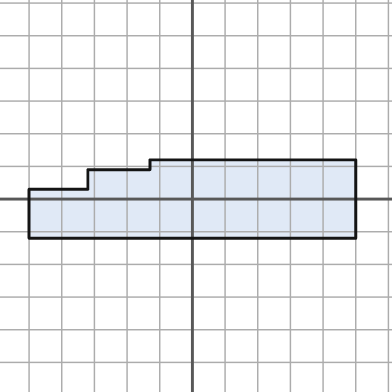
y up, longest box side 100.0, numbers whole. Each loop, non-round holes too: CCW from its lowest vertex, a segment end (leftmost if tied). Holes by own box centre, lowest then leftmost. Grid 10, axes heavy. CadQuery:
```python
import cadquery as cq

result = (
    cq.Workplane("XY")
    .moveTo(-50.0, -12.0)
    .lineTo(50.0, -12.0)
    .lineTo(50.0, 12.0)
    .lineTo(-13.0, 12.0)
    .lineTo(-13.0, 9.0)
    .lineTo(-32.0, 9.0)
    .lineTo(-32.0, 3.0)
    .lineTo(-50.0, 3.0)
    .close()
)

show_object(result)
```